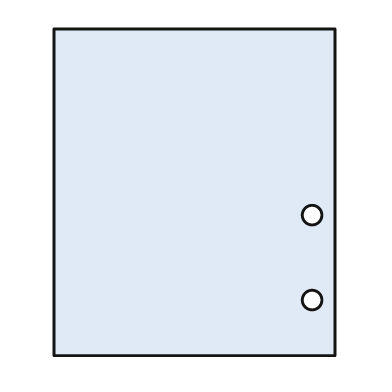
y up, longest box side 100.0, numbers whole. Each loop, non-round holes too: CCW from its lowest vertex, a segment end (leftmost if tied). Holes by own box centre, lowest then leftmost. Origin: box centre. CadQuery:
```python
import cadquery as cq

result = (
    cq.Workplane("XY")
    .moveTo(-43.0, -50.0)
    .lineTo(43.0, -50.0)
    .lineTo(43.0, 50.0)
    .lineTo(-43.0, 50.0)
    .close()
    .moveTo(36.0, -33.0)
    .circle(3.0)
    .moveTo(36.0, -7.0)
    .circle(3.0)
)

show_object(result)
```